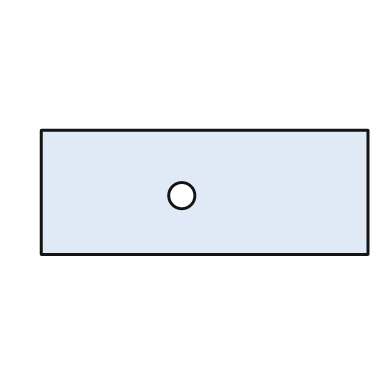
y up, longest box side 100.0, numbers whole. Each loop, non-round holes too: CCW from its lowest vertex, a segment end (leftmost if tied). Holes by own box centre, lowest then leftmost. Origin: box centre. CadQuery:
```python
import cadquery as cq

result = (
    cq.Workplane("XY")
    .moveTo(-50.0, -19.0)
    .lineTo(50.0, -19.0)
    .lineTo(50.0, 19.0)
    .lineTo(-50.0, 19.0)
    .close()
    .moveTo(-7.0, -1.0)
    .circle(4.0)
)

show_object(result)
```